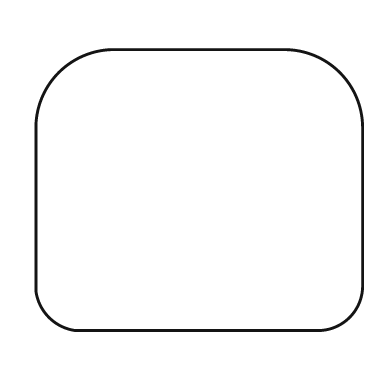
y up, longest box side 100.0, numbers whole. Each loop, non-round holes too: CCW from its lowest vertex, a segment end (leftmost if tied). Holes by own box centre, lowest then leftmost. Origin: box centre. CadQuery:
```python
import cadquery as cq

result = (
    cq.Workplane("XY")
    .moveTo(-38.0, -43.0)
    .lineTo(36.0, -43.0)
    .threePointArc((46.0, -39.0), (50.0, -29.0))
    .lineTo(50.0, 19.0)
    .threePointArc((43.0, 36.0), (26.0, 43.0))
    .lineTo(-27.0, 43.0)
    .threePointArc((-43.0, 36.0), (-50.0, 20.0))
    .lineTo(-50.0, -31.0)
    .threePointArc((-46.0, -39.0), (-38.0, -43.0))
    .close()
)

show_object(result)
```